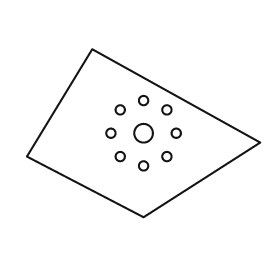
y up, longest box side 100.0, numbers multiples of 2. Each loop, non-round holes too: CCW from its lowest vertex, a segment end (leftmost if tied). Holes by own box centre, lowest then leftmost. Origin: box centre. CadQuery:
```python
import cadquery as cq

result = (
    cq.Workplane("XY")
    .moveTo(0.0, -36.0)
    .lineTo(50.0, -4.0)
    .lineTo(-22.0, 36.0)
    .lineTo(-50.0, -10.0)
    .close()
    .moveTo(0.0, -14.0)
    .circle(2.0)
    .moveTo(-10.0, -10.0)
    .circle(2.0)
    .moveTo(10.0, -10.0)
    .circle(2.0)
    .moveTo(-14.0, 0.0)
    .circle(2.0)
    .moveTo(0.0, 0.0)
    .circle(4.0)
    .moveTo(14.0, 0.0)
    .circle(2.0)
    .moveTo(-10.0, 10.0)
    .circle(2.0)
    .moveTo(10.0, 10.0)
    .circle(2.0)
    .moveTo(0.0, 14.0)
    .circle(2.0)
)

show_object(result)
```